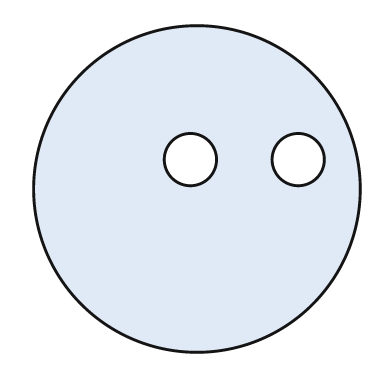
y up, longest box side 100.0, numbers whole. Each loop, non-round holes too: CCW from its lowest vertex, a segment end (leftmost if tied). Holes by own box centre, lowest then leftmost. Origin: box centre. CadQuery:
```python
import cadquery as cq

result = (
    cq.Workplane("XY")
    .moveTo(0.0, 0.0)
    .circle(50.0)
    .moveTo(-2.0, 9.0)
    .circle(8.0)
    .moveTo(31.0, 9.0)
    .circle(8.0)
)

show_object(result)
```